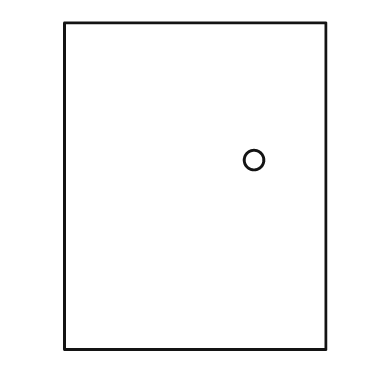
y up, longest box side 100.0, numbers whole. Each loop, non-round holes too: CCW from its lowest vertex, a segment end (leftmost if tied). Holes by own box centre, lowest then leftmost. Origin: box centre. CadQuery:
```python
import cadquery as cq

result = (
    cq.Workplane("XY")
    .moveTo(-40.0, -50.0)
    .lineTo(40.0, -50.0)
    .lineTo(40.0, 50.0)
    .lineTo(-40.0, 50.0)
    .close()
    .moveTo(18.0, 8.0)
    .circle(3.0)
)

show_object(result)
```